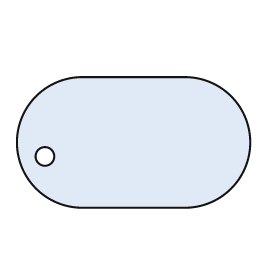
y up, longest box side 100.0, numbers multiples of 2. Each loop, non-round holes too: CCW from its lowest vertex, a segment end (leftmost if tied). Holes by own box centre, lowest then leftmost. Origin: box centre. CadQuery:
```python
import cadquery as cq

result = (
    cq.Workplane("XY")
    .moveTo(-22.0, -28.0)
    .lineTo(22.0, -28.0)
    .threePointArc((50.0, 0.0), (22.0, 28.0))
    .lineTo(-22.0, 28.0)
    .threePointArc((-50.0, 0.0), (-22.0, -28.0))
    .close()
    .moveTo(-38.0, -6.0)
    .circle(4.0)
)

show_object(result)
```